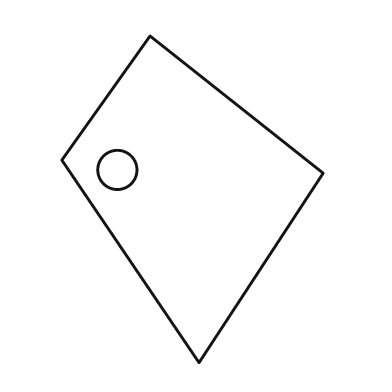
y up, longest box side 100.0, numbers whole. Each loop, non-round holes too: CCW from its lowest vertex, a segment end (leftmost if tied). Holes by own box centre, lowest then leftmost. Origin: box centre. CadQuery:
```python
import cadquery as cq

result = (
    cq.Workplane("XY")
    .moveTo(2.0, -50.0)
    .lineTo(40.0, 8.0)
    .lineTo(-13.0, 50.0)
    .lineTo(-40.0, 12.0)
    .close()
    .moveTo(-23.0, 9.0)
    .circle(6.0)
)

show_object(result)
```